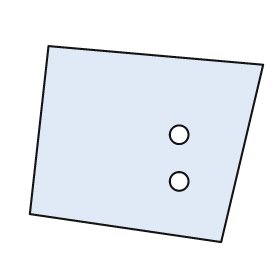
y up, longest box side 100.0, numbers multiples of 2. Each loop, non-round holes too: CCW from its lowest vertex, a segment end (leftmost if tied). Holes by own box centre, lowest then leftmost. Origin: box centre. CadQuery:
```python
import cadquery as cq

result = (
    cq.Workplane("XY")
    .moveTo(32.0, -42.0)
    .lineTo(50.0, 34.0)
    .lineTo(-42.0, 42.0)
    .lineTo(-50.0, -30.0)
    .close()
    .moveTo(14.0, -16.0)
    .circle(4.0)
    .moveTo(14.0, 4.0)
    .circle(4.0)
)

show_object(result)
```